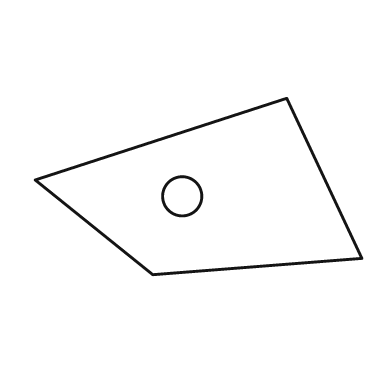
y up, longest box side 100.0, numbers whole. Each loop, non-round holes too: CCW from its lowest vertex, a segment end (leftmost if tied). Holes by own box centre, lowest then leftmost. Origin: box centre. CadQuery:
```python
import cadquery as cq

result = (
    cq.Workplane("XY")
    .moveTo(-14.0, -27.0)
    .lineTo(50.0, -22.0)
    .lineTo(27.0, 27.0)
    .lineTo(-50.0, 2.0)
    .close()
    .moveTo(-5.0, -3.0)
    .circle(6.0)
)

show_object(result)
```